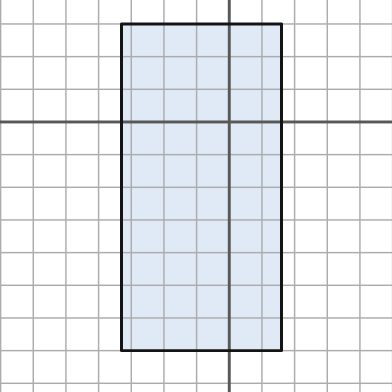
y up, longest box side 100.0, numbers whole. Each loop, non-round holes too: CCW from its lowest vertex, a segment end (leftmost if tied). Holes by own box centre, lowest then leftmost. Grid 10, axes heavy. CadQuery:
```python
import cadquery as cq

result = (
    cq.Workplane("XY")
    .moveTo(-33.0, -70.0)
    .lineTo(16.0, -70.0)
    .lineTo(16.0, 30.0)
    .lineTo(-33.0, 30.0)
    .close()
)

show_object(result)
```